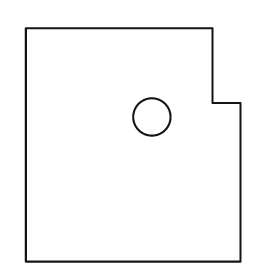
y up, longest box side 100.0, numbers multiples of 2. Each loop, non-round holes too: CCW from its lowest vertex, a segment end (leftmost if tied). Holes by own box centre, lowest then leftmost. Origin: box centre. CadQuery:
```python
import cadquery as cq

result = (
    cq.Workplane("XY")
    .moveTo(-46.0, -50.0)
    .lineTo(46.0, -50.0)
    .lineTo(46.0, 18.0)
    .lineTo(34.0, 18.0)
    .lineTo(34.0, 50.0)
    .lineTo(-46.0, 50.0)
    .close()
    .moveTo(8.0, 12.0)
    .circle(8.0)
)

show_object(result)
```